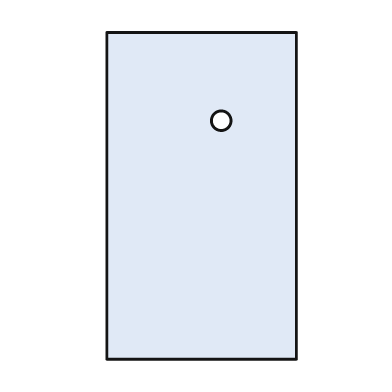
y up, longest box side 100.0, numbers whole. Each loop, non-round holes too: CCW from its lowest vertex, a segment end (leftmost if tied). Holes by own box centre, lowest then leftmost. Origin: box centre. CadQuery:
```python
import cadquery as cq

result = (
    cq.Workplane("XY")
    .moveTo(-29.0, -50.0)
    .lineTo(29.0, -50.0)
    .lineTo(29.0, 50.0)
    .lineTo(-29.0, 50.0)
    .close()
    .moveTo(6.0, 23.0)
    .circle(3.0)
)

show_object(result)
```